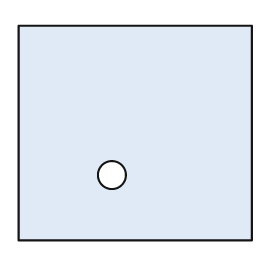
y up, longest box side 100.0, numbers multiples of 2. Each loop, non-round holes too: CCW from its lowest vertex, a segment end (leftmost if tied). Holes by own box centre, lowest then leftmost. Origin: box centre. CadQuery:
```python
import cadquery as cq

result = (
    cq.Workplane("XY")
    .moveTo(-50.0, -46.0)
    .lineTo(50.0, -46.0)
    .lineTo(50.0, 46.0)
    .lineTo(-50.0, 46.0)
    .close()
    .moveTo(-10.0, -18.0)
    .circle(6.0)
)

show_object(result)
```